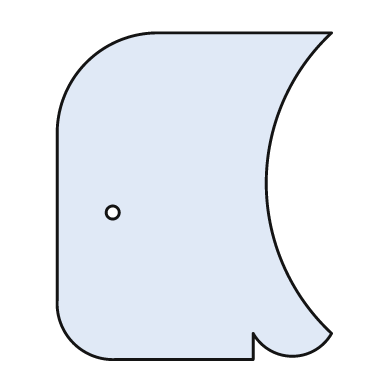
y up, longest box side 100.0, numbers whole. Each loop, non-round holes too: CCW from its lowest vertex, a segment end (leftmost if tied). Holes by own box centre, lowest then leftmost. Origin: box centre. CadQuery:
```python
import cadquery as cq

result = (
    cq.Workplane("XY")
    .moveTo(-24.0, -50.0)
    .lineTo(18.0, -50.0)
    .lineTo(18.0, -42.0)
    .threePointArc((30.0, -49.0), (42.0, -42.0))
    .threePointArc((22.0, 4.0), (42.0, 50.0))
    .lineTo(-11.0, 50.0)
    .threePointArc((-33.0, 41.0), (-42.0, 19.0))
    .lineTo(-42.0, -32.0)
    .threePointArc((-37.0, -45.0), (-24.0, -50.0))
    .close()
    .moveTo(-25.0, -5.0)
    .circle(2.0)
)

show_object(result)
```